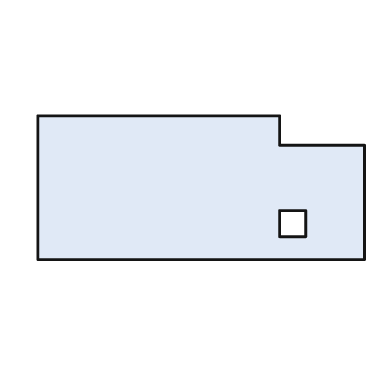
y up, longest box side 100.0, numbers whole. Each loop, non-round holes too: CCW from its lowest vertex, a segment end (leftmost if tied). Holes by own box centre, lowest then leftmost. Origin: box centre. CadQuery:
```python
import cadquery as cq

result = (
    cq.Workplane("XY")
    .moveTo(-50.0, -22.0)
    .lineTo(50.0, -22.0)
    .lineTo(50.0, 13.0)
    .lineTo(24.0, 13.0)
    .lineTo(24.0, 22.0)
    .lineTo(-50.0, 22.0)
    .close()
    .moveTo(24.0, -15.0)
    .lineTo(32.0, -15.0)
    .lineTo(32.0, -7.0)
    .lineTo(24.0, -7.0)
    .close()
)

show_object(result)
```